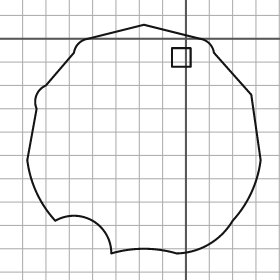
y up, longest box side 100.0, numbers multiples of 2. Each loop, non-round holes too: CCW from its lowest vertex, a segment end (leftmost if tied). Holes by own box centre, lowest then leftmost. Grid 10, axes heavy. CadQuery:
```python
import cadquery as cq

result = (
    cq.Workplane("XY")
    .moveTo(-32.0, -92.0)
    .threePointArc((-18.0, -90.0), (-4.0, -92.0))
    .threePointArc((10.0, -88.0), (20.0, -78.0))
    .threePointArc((28.0, -66.0), (32.0, -52.0))
    .lineTo(28.0, -24.0)
    .lineTo(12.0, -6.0)
    .threePointArc((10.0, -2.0), (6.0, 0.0))
    .lineTo(-18.0, 6.0)
    .lineTo(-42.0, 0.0)
    .threePointArc((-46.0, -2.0), (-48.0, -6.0))
    .lineTo(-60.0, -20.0)
    .threePointArc((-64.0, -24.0), (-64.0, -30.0))
    .lineTo(-68.0, -52.0)
    .threePointArc((-64.0, -66.0), (-56.0, -78.0))
    .threePointArc((-40.0, -78.0), (-32.0, -92.0))
    .close()
    .moveTo(-6.0, -12.0)
    .lineTo(2.0, -12.0)
    .lineTo(2.0, -4.0)
    .lineTo(-6.0, -4.0)
    .close()
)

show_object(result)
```